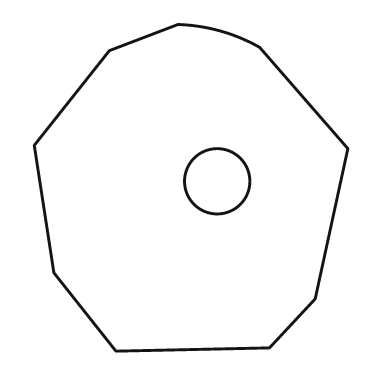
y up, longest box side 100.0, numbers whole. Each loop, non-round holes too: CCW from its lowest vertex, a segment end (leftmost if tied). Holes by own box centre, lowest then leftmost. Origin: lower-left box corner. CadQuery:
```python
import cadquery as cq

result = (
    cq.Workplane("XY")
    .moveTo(25.0, 0.0)
    .lineTo(72.0, 1.0)
    .lineTo(86.0, 16.0)
    .lineTo(96.0, 62.0)
    .lineTo(69.0, 93.0)
    .threePointArc((57.0, 98.0), (44.0, 100.0))
    .lineTo(23.0, 92.0)
    .lineTo(0.0, 63.0)
    .lineTo(6.0, 24.0)
    .close()
    .moveTo(56.0, 52.0)
    .circle(10.0)
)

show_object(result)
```